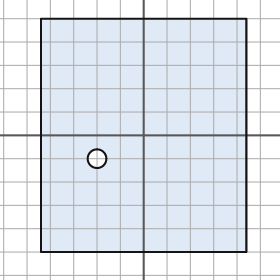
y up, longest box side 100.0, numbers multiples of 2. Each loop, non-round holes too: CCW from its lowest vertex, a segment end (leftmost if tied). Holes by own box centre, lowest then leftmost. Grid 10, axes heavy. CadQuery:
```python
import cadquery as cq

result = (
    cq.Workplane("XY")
    .moveTo(-44.0, -50.0)
    .lineTo(44.0, -50.0)
    .lineTo(44.0, 50.0)
    .lineTo(-44.0, 50.0)
    .close()
    .moveTo(-20.0, -10.0)
    .circle(4.0)
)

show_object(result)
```